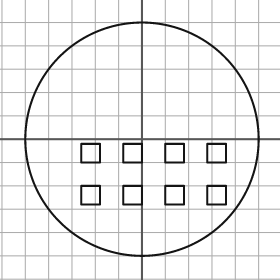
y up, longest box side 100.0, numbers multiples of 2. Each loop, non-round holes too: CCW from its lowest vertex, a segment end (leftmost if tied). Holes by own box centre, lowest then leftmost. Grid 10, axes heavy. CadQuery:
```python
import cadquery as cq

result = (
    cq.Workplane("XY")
    .moveTo(0.0, 0.0)
    .circle(50.0)
    .moveTo(-26.0, -28.0)
    .lineTo(-18.0, -28.0)
    .lineTo(-18.0, -20.0)
    .lineTo(-26.0, -20.0)
    .close()
    .moveTo(-8.0, -28.0)
    .lineTo(0.0, -28.0)
    .lineTo(0.0, -20.0)
    .lineTo(-8.0, -20.0)
    .close()
    .moveTo(10.0, -28.0)
    .lineTo(18.0, -28.0)
    .lineTo(18.0, -20.0)
    .lineTo(10.0, -20.0)
    .close()
    .moveTo(28.0, -28.0)
    .lineTo(36.0, -28.0)
    .lineTo(36.0, -20.0)
    .lineTo(28.0, -20.0)
    .close()
    .moveTo(-26.0, -10.0)
    .lineTo(-18.0, -10.0)
    .lineTo(-18.0, -2.0)
    .lineTo(-26.0, -2.0)
    .close()
    .moveTo(-8.0, -10.0)
    .lineTo(0.0, -10.0)
    .lineTo(0.0, -2.0)
    .lineTo(-8.0, -2.0)
    .close()
    .moveTo(10.0, -10.0)
    .lineTo(18.0, -10.0)
    .lineTo(18.0, -2.0)
    .lineTo(10.0, -2.0)
    .close()
    .moveTo(28.0, -10.0)
    .lineTo(36.0, -10.0)
    .lineTo(36.0, -2.0)
    .lineTo(28.0, -2.0)
    .close()
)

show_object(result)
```